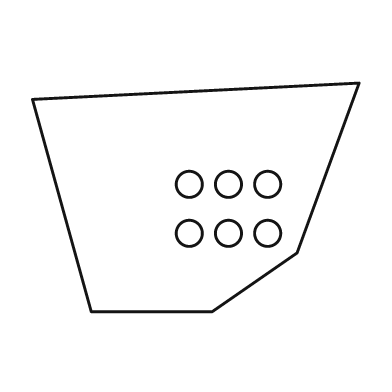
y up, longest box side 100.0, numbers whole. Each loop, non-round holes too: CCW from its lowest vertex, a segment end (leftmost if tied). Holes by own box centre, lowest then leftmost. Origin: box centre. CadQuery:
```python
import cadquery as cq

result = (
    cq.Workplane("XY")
    .moveTo(-32.0, -35.0)
    .lineTo(5.0, -35.0)
    .lineTo(31.0, -17.0)
    .lineTo(50.0, 35.0)
    .lineTo(-50.0, 30.0)
    .close()
    .moveTo(-2.0, -11.0)
    .circle(4.0)
    .moveTo(10.0, -11.0)
    .circle(4.0)
    .moveTo(22.0, -11.0)
    .circle(4.0)
    .moveTo(-2.0, 4.0)
    .circle(4.0)
    .moveTo(10.0, 4.0)
    .circle(4.0)
    .moveTo(22.0, 4.0)
    .circle(4.0)
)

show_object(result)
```